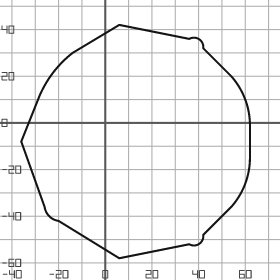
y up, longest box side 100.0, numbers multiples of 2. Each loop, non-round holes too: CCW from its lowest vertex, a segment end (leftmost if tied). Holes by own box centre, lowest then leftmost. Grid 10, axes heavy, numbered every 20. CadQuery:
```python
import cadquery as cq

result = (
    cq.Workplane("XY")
    .moveTo(6.0, -58.0)
    .lineTo(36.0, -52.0)
    .threePointArc((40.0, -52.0), (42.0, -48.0))
    .lineTo(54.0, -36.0)
    .threePointArc((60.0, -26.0), (62.0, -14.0))
    .lineTo(62.0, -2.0)
    .threePointArc((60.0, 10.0), (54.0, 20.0))
    .lineTo(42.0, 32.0)
    .threePointArc((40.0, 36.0), (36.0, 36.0))
    .lineTo(6.0, 42.0)
    .lineTo(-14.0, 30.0)
    .threePointArc((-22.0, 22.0), (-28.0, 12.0))
    .lineTo(-36.0, -8.0)
    .lineTo(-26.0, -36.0)
    .threePointArc((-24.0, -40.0), (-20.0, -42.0))
    .close()
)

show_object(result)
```